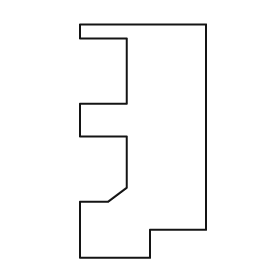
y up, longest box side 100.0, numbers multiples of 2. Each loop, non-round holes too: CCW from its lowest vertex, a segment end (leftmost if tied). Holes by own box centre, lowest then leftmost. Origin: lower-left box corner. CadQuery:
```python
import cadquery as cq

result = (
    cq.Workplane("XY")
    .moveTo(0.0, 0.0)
    .lineTo(30.0, 0.0)
    .lineTo(30.0, 12.0)
    .lineTo(54.0, 12.0)
    .lineTo(54.0, 100.0)
    .lineTo(0.0, 100.0)
    .lineTo(0.0, 94.0)
    .lineTo(20.0, 94.0)
    .lineTo(20.0, 66.0)
    .lineTo(0.0, 66.0)
    .lineTo(0.0, 52.0)
    .lineTo(20.0, 52.0)
    .lineTo(20.0, 30.0)
    .lineTo(12.0, 24.0)
    .lineTo(0.0, 24.0)
    .close()
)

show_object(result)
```